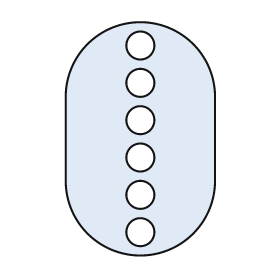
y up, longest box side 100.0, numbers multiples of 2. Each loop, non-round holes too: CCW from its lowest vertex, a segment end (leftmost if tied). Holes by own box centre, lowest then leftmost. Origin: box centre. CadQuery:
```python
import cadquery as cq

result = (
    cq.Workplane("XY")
    .moveTo(-32.0, -18.0)
    .threePointArc((0.0, -50.0), (32.0, -18.0))
    .lineTo(32.0, 18.0)
    .threePointArc((0.0, 50.0), (-32.0, 18.0))
    .close()
    .moveTo(0.0, -40.0)
    .circle(6.0)
    .moveTo(0.0, -24.0)
    .circle(6.0)
    .moveTo(0.0, -8.0)
    .circle(6.0)
    .moveTo(0.0, 8.0)
    .circle(6.0)
    .moveTo(0.0, 24.0)
    .circle(6.0)
    .moveTo(0.0, 40.0)
    .circle(6.0)
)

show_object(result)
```